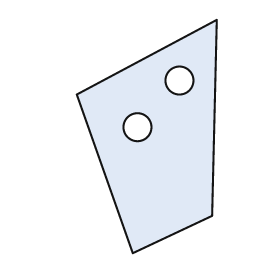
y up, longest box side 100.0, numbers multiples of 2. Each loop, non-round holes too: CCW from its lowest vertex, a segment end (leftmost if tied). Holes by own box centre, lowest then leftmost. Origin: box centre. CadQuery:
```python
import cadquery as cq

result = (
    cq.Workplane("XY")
    .moveTo(-6.0, -50.0)
    .lineTo(28.0, -34.0)
    .lineTo(30.0, 50.0)
    .lineTo(-30.0, 18.0)
    .close()
    .moveTo(-4.0, 4.0)
    .circle(6.0)
    .moveTo(14.0, 24.0)
    .circle(6.0)
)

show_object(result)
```